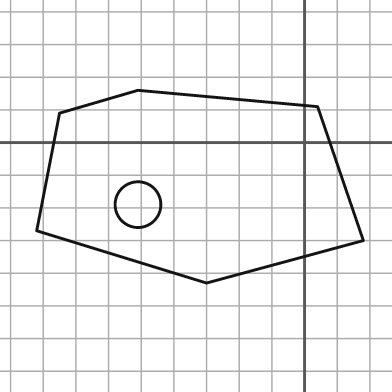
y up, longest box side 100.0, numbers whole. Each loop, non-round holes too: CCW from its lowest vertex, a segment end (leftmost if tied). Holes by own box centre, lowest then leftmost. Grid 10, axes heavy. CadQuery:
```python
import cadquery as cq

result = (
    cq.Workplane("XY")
    .moveTo(-30.0, -43.0)
    .lineTo(18.0, -30.0)
    .lineTo(4.0, 11.0)
    .lineTo(-51.0, 16.0)
    .lineTo(-75.0, 9.0)
    .lineTo(-82.0, -27.0)
    .close()
    .moveTo(-51.0, -19.0)
    .circle(7.0)
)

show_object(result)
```